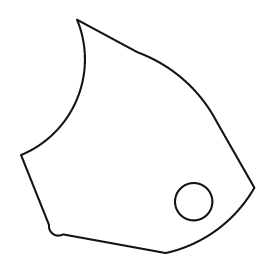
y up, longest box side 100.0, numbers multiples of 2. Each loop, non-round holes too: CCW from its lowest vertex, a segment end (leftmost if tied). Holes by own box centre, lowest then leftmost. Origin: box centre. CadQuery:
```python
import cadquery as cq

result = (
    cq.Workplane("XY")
    .moveTo(12.0, -50.0)
    .threePointArc((34.0, -40.0), (50.0, -22.0))
    .lineTo(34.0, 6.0)
    .threePointArc((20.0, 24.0), (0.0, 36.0))
    .lineTo(-26.0, 50.0)
    .threePointArc((-26.0, 16.0), (-50.0, -8.0))
    .lineTo(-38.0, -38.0)
    .threePointArc((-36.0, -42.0), (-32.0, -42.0))
    .close()
    .moveTo(24.0, -28.0)
    .circle(8.0)
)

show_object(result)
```